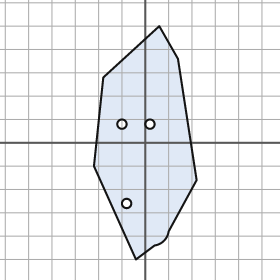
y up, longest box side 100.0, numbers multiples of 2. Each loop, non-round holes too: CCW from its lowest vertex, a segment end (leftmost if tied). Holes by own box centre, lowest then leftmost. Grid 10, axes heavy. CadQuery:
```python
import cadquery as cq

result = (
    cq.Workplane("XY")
    .moveTo(-4.0, -50.0)
    .lineTo(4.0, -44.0)
    .threePointArc((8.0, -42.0), (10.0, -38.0))
    .lineTo(22.0, -16.0)
    .lineTo(14.0, 36.0)
    .lineTo(6.0, 50.0)
    .lineTo(-18.0, 28.0)
    .lineTo(-22.0, -10.0)
    .close()
    .moveTo(-8.0, -26.0)
    .circle(2.0)
    .moveTo(-10.0, 8.0)
    .circle(2.0)
    .moveTo(2.0, 8.0)
    .circle(2.0)
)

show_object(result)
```